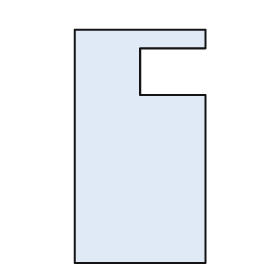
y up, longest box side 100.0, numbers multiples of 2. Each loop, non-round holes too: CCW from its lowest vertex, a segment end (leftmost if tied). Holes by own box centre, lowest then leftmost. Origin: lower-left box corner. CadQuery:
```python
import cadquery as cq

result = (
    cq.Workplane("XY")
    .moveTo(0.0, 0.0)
    .lineTo(56.0, 0.0)
    .lineTo(56.0, 72.0)
    .lineTo(28.0, 72.0)
    .lineTo(28.0, 92.0)
    .lineTo(56.0, 92.0)
    .lineTo(56.0, 100.0)
    .lineTo(0.0, 100.0)
    .close()
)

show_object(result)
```